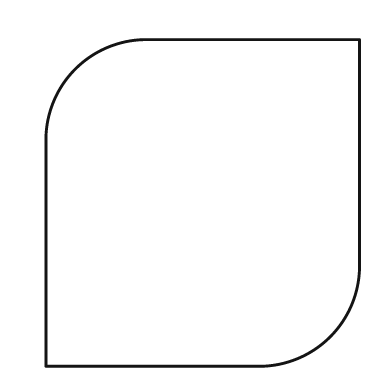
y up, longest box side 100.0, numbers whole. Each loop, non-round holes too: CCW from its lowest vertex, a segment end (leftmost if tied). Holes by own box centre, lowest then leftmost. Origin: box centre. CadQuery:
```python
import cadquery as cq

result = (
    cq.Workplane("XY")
    .moveTo(-48.0, -50.0)
    .lineTo(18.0, -50.0)
    .threePointArc((39.0, -41.0), (48.0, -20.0))
    .lineTo(48.0, 50.0)
    .lineTo(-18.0, 50.0)
    .threePointArc((-39.0, 41.0), (-48.0, 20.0))
    .close()
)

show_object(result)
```